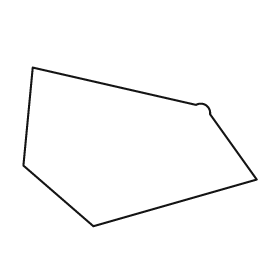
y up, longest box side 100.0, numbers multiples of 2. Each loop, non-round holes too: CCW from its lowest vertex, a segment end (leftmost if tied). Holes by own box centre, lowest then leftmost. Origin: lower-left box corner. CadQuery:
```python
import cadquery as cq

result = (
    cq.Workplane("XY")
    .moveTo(30.0, 0.0)
    .lineTo(100.0, 20.0)
    .lineTo(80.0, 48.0)
    .threePointArc((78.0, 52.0), (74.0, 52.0))
    .lineTo(4.0, 68.0)
    .lineTo(0.0, 26.0)
    .close()
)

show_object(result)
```